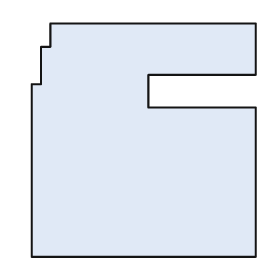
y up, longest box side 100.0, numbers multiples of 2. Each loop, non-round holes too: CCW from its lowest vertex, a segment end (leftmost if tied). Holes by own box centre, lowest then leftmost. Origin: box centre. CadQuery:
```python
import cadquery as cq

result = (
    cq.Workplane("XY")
    .moveTo(-48.0, -50.0)
    .lineTo(48.0, -50.0)
    .lineTo(48.0, 14.0)
    .lineTo(2.0, 14.0)
    .lineTo(2.0, 28.0)
    .lineTo(48.0, 28.0)
    .lineTo(48.0, 50.0)
    .lineTo(-40.0, 50.0)
    .lineTo(-40.0, 40.0)
    .lineTo(-44.0, 40.0)
    .lineTo(-44.0, 24.0)
    .lineTo(-48.0, 24.0)
    .close()
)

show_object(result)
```